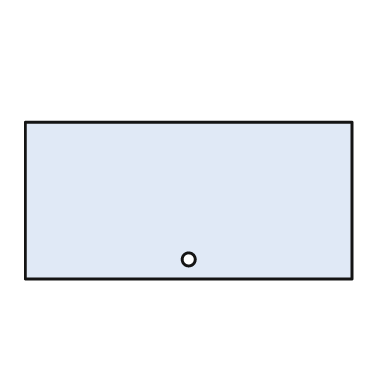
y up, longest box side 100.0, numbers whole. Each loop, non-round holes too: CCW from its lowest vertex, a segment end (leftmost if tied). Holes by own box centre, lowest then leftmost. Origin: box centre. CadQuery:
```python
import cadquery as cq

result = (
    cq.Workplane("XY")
    .moveTo(-50.0, -24.0)
    .lineTo(50.0, -24.0)
    .lineTo(50.0, 24.0)
    .lineTo(-50.0, 24.0)
    .close()
    .moveTo(0.0, -18.0)
    .circle(2.0)
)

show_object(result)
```